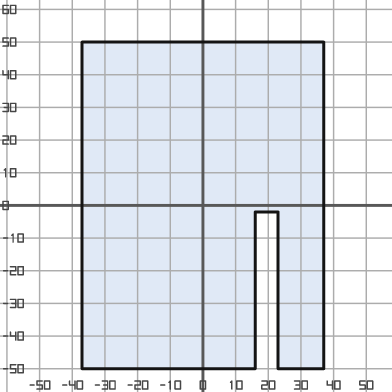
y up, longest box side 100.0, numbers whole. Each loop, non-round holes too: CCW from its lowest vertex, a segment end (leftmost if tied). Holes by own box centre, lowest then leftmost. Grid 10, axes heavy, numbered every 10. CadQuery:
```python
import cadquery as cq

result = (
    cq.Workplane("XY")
    .moveTo(-37.0, -50.0)
    .lineTo(16.0, -50.0)
    .lineTo(16.0, -2.0)
    .lineTo(23.0, -2.0)
    .lineTo(23.0, -50.0)
    .lineTo(37.0, -50.0)
    .lineTo(37.0, 50.0)
    .lineTo(-37.0, 50.0)
    .close()
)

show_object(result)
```